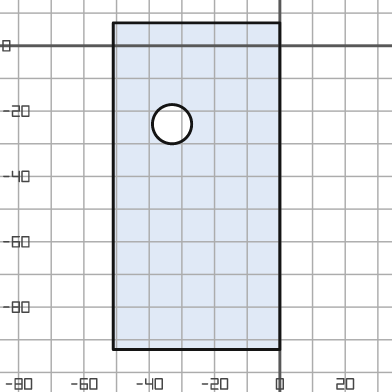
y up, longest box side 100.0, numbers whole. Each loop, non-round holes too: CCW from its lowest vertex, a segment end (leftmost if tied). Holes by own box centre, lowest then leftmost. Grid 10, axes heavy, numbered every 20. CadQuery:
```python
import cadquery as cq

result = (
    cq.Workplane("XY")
    .moveTo(-51.0, -93.0)
    .lineTo(0.0, -93.0)
    .lineTo(0.0, 7.0)
    .lineTo(-51.0, 7.0)
    .close()
    .moveTo(-33.0, -24.0)
    .circle(6.0)
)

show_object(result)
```